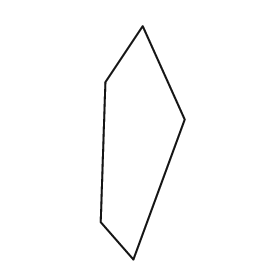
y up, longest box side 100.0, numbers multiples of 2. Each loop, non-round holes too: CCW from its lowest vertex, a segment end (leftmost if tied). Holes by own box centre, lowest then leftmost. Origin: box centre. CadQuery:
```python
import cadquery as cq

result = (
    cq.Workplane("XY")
    .moveTo(-4.0, -50.0)
    .lineTo(18.0, 10.0)
    .lineTo(0.0, 50.0)
    .lineTo(-16.0, 26.0)
    .lineTo(-18.0, -34.0)
    .close()
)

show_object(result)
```